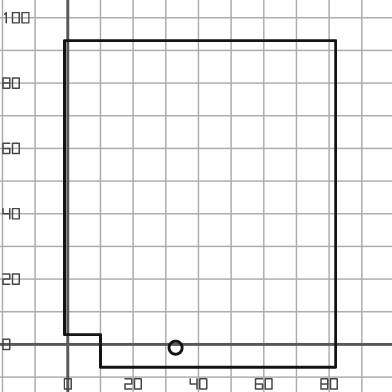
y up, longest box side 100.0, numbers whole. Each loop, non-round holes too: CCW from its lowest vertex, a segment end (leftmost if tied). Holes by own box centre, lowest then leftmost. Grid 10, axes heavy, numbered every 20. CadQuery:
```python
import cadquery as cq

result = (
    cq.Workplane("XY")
    .moveTo(10.0, -7.0)
    .lineTo(82.0, -7.0)
    .lineTo(82.0, 93.0)
    .lineTo(-1.0, 93.0)
    .lineTo(-1.0, 3.0)
    .lineTo(10.0, 3.0)
    .close()
    .moveTo(33.0, -1.0)
    .circle(2.0)
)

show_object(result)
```